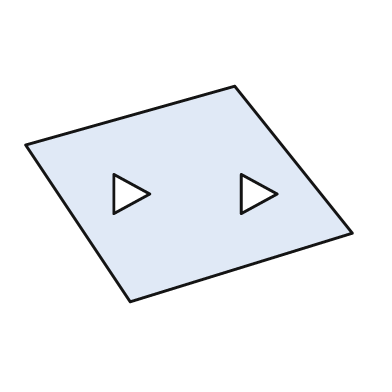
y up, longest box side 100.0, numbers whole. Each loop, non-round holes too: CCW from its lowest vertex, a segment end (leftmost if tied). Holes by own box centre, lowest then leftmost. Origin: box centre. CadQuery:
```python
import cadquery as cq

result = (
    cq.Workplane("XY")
    .moveTo(-18.0, -33.0)
    .lineTo(50.0, -12.0)
    .lineTo(14.0, 33.0)
    .lineTo(-50.0, 15.0)
    .close()
    .moveTo(-23.0, -6.0)
    .lineTo(-12.0, 0.0)
    .lineTo(-23.0, 6.0)
    .close()
    .moveTo(16.0, -6.0)
    .lineTo(27.0, 0.0)
    .lineTo(16.0, 6.0)
    .close()
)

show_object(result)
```